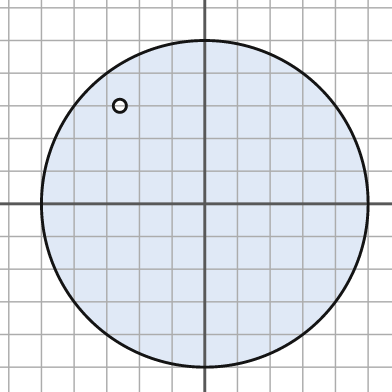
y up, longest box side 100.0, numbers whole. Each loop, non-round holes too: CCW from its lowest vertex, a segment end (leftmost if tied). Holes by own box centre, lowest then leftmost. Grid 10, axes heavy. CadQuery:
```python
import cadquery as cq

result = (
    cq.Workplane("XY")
    .moveTo(0.0, 0.0)
    .circle(50.0)
    .moveTo(-26.0, 30.0)
    .circle(2.0)
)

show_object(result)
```